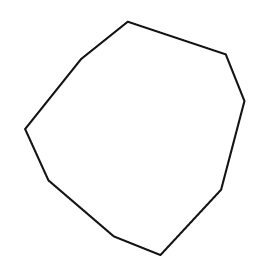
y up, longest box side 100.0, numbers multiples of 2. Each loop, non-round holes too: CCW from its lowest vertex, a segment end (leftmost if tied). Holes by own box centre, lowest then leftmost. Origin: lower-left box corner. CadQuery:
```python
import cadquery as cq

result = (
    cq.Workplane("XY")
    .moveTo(58.0, 0.0)
    .lineTo(84.0, 28.0)
    .lineTo(94.0, 66.0)
    .lineTo(86.0, 86.0)
    .lineTo(44.0, 100.0)
    .lineTo(24.0, 84.0)
    .lineTo(0.0, 54.0)
    .lineTo(10.0, 32.0)
    .lineTo(38.0, 8.0)
    .close()
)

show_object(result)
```